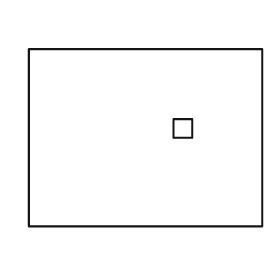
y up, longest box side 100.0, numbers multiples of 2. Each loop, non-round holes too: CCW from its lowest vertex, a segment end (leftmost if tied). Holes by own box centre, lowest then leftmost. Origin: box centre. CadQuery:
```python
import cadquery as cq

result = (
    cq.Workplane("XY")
    .moveTo(-50.0, -38.0)
    .lineTo(50.0, -38.0)
    .lineTo(50.0, 38.0)
    .lineTo(-50.0, 38.0)
    .close()
    .moveTo(12.0, 0.0)
    .lineTo(20.0, 0.0)
    .lineTo(20.0, 8.0)
    .lineTo(12.0, 8.0)
    .close()
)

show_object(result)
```